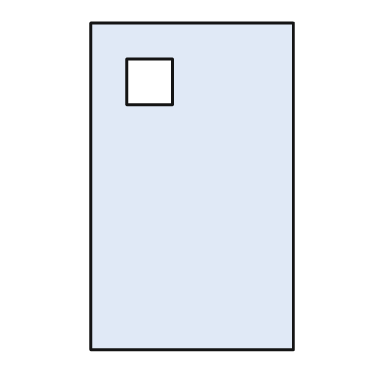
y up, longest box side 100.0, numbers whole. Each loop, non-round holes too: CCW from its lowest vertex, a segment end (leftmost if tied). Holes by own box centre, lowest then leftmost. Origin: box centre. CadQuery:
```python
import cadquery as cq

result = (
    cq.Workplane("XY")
    .moveTo(-31.0, -50.0)
    .lineTo(31.0, -50.0)
    .lineTo(31.0, 50.0)
    .lineTo(-31.0, 50.0)
    .close()
    .moveTo(-20.0, 25.0)
    .lineTo(-6.0, 25.0)
    .lineTo(-6.0, 39.0)
    .lineTo(-20.0, 39.0)
    .close()
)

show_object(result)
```